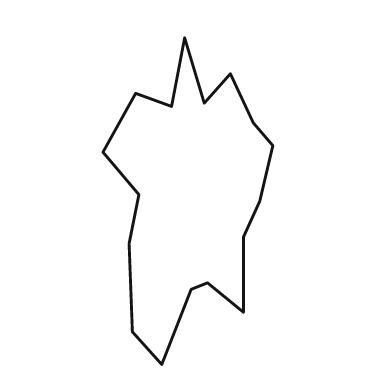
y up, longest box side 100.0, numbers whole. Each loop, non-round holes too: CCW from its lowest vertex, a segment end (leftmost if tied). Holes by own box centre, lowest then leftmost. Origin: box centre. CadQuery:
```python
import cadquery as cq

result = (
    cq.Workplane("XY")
    .moveTo(-8.0, -50.0)
    .lineTo(1.0, -27.0)
    .lineTo(6.0, -25.0)
    .lineTo(17.0, -34.0)
    .lineTo(17.0, -11.0)
    .lineTo(22.0, 0.0)
    .lineTo(26.0, 17.0)
    .lineTo(20.0, 24.0)
    .lineTo(13.0, 39.0)
    .lineTo(5.0, 30.0)
    .lineTo(-1.0, 50.0)
    .lineTo(-5.0, 29.0)
    .lineTo(-16.0, 33.0)
    .lineTo(-26.0, 15.0)
    .lineTo(-15.0, 2.0)
    .lineTo(-18.0, -13.0)
    .lineTo(-17.0, -40.0)
    .close()
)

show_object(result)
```